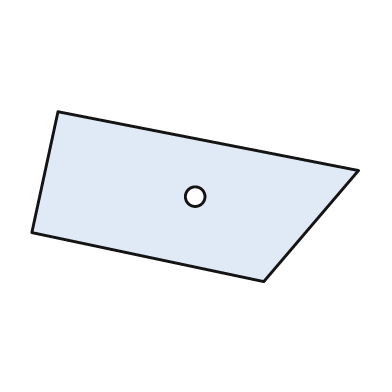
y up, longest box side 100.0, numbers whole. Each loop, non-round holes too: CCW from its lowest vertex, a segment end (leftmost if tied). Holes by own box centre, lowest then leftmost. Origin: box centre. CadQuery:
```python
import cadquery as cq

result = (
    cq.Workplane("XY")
    .moveTo(21.0, -26.0)
    .lineTo(50.0, 8.0)
    .lineTo(-42.0, 26.0)
    .lineTo(-50.0, -11.0)
    .close()
    .moveTo(0.0, 0.0)
    .circle(3.0)
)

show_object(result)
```